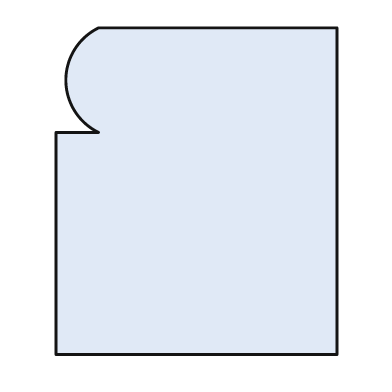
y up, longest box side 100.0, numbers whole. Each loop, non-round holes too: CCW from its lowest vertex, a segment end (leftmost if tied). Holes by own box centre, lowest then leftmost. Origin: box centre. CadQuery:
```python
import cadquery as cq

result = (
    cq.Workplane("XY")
    .moveTo(-43.0, -50.0)
    .lineTo(43.0, -50.0)
    .lineTo(43.0, 50.0)
    .lineTo(-30.0, 50.0)
    .threePointArc((-40.0, 34.0), (-30.0, 18.0))
    .lineTo(-43.0, 18.0)
    .close()
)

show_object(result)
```